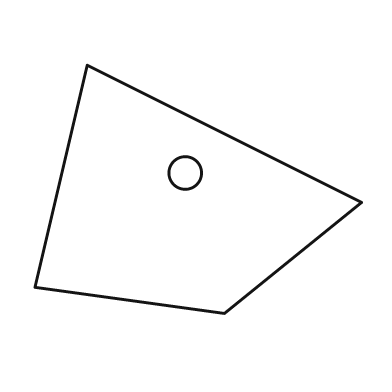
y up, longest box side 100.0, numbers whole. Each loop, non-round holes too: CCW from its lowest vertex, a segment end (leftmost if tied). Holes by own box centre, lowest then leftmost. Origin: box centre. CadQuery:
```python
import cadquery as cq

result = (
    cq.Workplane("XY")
    .moveTo(8.0, -38.0)
    .lineTo(50.0, -4.0)
    .lineTo(-34.0, 38.0)
    .lineTo(-50.0, -30.0)
    .close()
    .moveTo(-4.0, 5.0)
    .circle(5.0)
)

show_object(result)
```